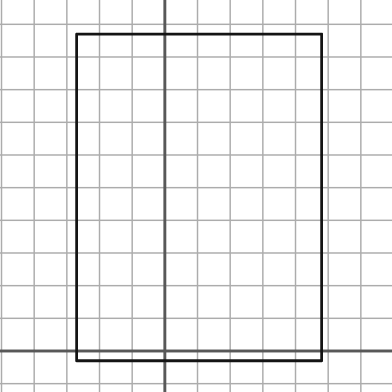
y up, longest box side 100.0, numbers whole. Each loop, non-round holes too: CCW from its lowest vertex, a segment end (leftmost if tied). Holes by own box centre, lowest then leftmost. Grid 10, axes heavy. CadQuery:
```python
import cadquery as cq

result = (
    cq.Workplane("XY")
    .moveTo(-27.0, -3.0)
    .lineTo(48.0, -3.0)
    .lineTo(48.0, 97.0)
    .lineTo(-27.0, 97.0)
    .close()
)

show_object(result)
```